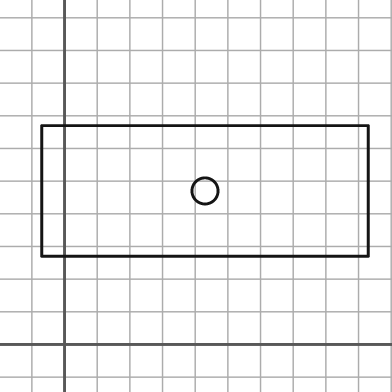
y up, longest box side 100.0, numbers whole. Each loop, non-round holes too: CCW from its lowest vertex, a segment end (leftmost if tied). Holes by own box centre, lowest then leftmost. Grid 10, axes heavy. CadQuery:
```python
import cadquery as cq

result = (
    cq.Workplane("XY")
    .moveTo(-7.0, 27.0)
    .lineTo(93.0, 27.0)
    .lineTo(93.0, 67.0)
    .lineTo(-7.0, 67.0)
    .close()
    .moveTo(43.0, 47.0)
    .circle(4.0)
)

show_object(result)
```